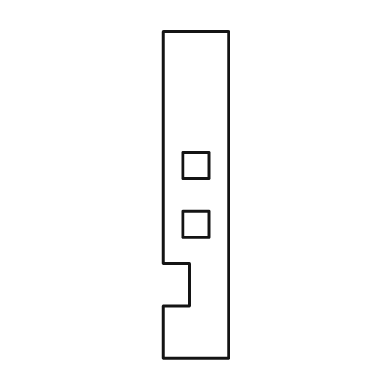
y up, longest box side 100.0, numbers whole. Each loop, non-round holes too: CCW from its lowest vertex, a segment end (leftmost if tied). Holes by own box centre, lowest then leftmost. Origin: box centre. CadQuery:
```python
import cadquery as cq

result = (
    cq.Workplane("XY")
    .moveTo(-10.0, -50.0)
    .lineTo(10.0, -50.0)
    .lineTo(10.0, 50.0)
    .lineTo(-10.0, 50.0)
    .lineTo(-10.0, -21.0)
    .lineTo(-2.0, -21.0)
    .lineTo(-2.0, -34.0)
    .lineTo(-10.0, -34.0)
    .close()
    .moveTo(-4.0, -13.0)
    .lineTo(4.0, -13.0)
    .lineTo(4.0, -5.0)
    .lineTo(-4.0, -5.0)
    .close()
    .moveTo(-4.0, 5.0)
    .lineTo(4.0, 5.0)
    .lineTo(4.0, 13.0)
    .lineTo(-4.0, 13.0)
    .close()
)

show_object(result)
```